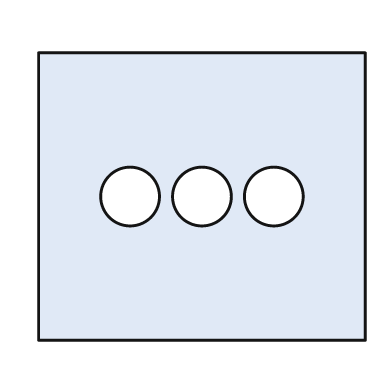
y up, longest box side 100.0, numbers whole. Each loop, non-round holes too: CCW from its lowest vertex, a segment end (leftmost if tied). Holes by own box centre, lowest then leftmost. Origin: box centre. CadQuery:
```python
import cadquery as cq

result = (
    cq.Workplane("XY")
    .moveTo(-50.0, -44.0)
    .lineTo(50.0, -44.0)
    .lineTo(50.0, 44.0)
    .lineTo(-50.0, 44.0)
    .close()
    .moveTo(-22.0, 0.0)
    .circle(9.0)
    .moveTo(0.0, 0.0)
    .circle(9.0)
    .moveTo(22.0, 0.0)
    .circle(9.0)
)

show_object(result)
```